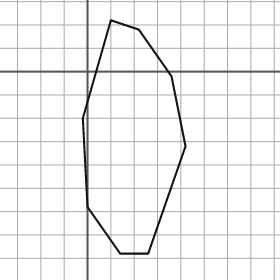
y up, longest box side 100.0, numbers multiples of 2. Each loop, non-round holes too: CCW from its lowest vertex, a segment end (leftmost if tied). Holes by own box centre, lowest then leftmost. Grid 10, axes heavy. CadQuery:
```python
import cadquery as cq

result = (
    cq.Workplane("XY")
    .moveTo(14.0, -78.0)
    .lineTo(26.0, -78.0)
    .lineTo(42.0, -32.0)
    .lineTo(36.0, -2.0)
    .lineTo(22.0, 18.0)
    .lineTo(10.0, 22.0)
    .lineTo(-2.0, -20.0)
    .lineTo(0.0, -58.0)
    .close()
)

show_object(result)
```